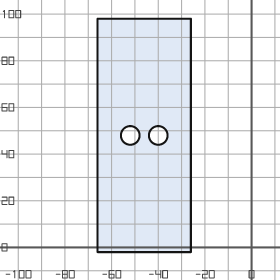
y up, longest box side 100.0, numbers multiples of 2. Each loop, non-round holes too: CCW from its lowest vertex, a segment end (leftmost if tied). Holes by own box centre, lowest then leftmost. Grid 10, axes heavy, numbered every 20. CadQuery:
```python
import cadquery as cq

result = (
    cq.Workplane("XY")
    .moveTo(-66.0, -2.0)
    .lineTo(-26.0, -2.0)
    .lineTo(-26.0, 98.0)
    .lineTo(-66.0, 98.0)
    .close()
    .moveTo(-52.0, 48.0)
    .circle(4.0)
    .moveTo(-40.0, 48.0)
    .circle(4.0)
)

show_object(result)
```